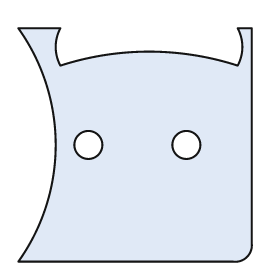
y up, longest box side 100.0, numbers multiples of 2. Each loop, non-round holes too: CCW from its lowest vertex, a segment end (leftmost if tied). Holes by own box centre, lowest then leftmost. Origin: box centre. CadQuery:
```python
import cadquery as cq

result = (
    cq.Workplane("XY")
    .moveTo(-50.0, -50.0)
    .lineTo(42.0, -50.0)
    .threePointArc((48.0, -48.0), (50.0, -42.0))
    .lineTo(50.0, 50.0)
    .lineTo(44.0, 50.0)
    .threePointArc((46.0, 42.0), (44.0, 34.0))
    .threePointArc((6.0, 40.0), (-32.0, 34.0))
    .threePointArc((-34.0, 42.0), (-32.0, 50.0))
    .lineTo(-50.0, 50.0)
    .threePointArc((-34.0, 0.0), (-50.0, -50.0))
    .close()
    .moveTo(-20.0, 0.0)
    .circle(6.0)
    .moveTo(22.0, 0.0)
    .circle(6.0)
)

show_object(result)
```